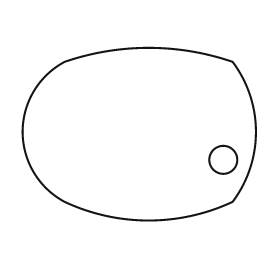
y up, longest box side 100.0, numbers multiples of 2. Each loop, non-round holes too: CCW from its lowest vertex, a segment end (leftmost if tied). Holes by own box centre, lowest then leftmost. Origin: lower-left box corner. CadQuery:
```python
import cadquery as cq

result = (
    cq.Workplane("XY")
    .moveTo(18.0, 8.0)
    .threePointArc((54.0, 0.0), (90.0, 8.0))
    .threePointArc((100.0, 38.0), (90.0, 68.0))
    .threePointArc((54.0, 74.0), (18.0, 68.0))
    .threePointArc((0.0, 38.0), (18.0, 8.0))
    .close()
    .moveTo(86.0, 26.0)
    .circle(6.0)
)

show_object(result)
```